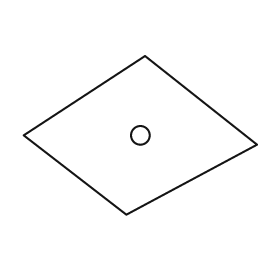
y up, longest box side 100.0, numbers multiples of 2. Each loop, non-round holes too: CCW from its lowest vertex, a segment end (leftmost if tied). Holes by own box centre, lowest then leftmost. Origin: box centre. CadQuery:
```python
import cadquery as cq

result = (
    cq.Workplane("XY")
    .moveTo(-6.0, -34.0)
    .lineTo(50.0, -4.0)
    .lineTo(2.0, 34.0)
    .lineTo(-50.0, 0.0)
    .close()
    .moveTo(0.0, 0.0)
    .circle(4.0)
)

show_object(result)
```